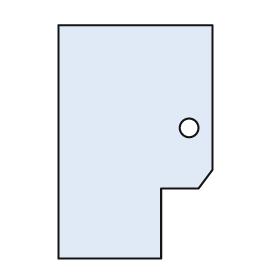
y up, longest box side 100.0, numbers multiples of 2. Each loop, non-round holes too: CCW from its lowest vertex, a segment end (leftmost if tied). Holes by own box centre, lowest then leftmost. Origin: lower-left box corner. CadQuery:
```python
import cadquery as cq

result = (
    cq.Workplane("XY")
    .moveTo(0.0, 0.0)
    .lineTo(44.0, 0.0)
    .lineTo(44.0, 30.0)
    .lineTo(60.0, 30.0)
    .lineTo(66.0, 38.0)
    .lineTo(66.0, 100.0)
    .lineTo(0.0, 100.0)
    .close()
    .moveTo(56.0, 56.0)
    .circle(4.0)
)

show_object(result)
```